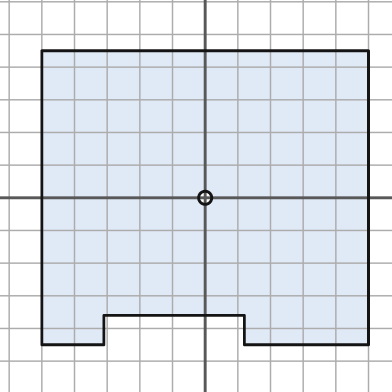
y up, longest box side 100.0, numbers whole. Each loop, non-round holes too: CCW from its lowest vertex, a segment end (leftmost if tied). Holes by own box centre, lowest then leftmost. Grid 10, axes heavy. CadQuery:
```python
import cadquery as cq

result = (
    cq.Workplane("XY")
    .moveTo(-50.0, -45.0)
    .lineTo(-31.0, -45.0)
    .lineTo(-31.0, -36.0)
    .lineTo(12.0, -36.0)
    .lineTo(12.0, -45.0)
    .lineTo(50.0, -45.0)
    .lineTo(50.0, 45.0)
    .lineTo(-50.0, 45.0)
    .close()
    .moveTo(0.0, 0.0)
    .circle(2.0)
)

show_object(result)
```